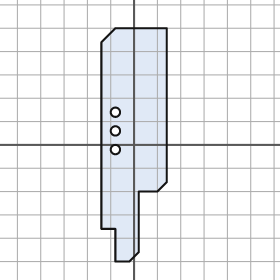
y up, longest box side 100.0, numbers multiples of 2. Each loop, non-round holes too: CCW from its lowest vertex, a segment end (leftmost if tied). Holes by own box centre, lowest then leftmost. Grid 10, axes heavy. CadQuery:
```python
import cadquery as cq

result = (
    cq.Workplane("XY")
    .moveTo(-8.0, -50.0)
    .lineTo(-2.0, -50.0)
    .lineTo(2.0, -46.0)
    .lineTo(2.0, -20.0)
    .lineTo(10.0, -20.0)
    .lineTo(14.0, -16.0)
    .lineTo(14.0, 50.0)
    .lineTo(-8.0, 50.0)
    .lineTo(-14.0, 44.0)
    .lineTo(-14.0, -36.0)
    .lineTo(-8.0, -36.0)
    .close()
    .moveTo(-8.0, -2.0)
    .circle(2.0)
    .moveTo(-8.0, 6.0)
    .circle(2.0)
    .moveTo(-8.0, 14.0)
    .circle(2.0)
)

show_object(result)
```